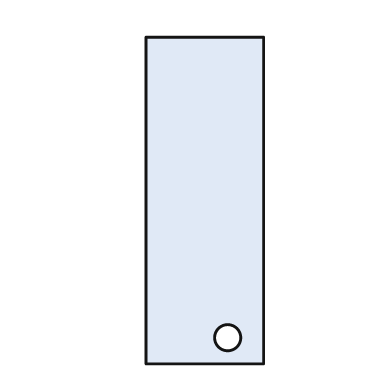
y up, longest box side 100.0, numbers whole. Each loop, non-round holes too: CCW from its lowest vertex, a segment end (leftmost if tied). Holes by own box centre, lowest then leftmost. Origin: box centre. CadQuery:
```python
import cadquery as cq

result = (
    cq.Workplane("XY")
    .moveTo(-18.0, -50.0)
    .lineTo(18.0, -50.0)
    .lineTo(18.0, 50.0)
    .lineTo(-18.0, 50.0)
    .close()
    .moveTo(7.0, -42.0)
    .circle(4.0)
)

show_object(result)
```